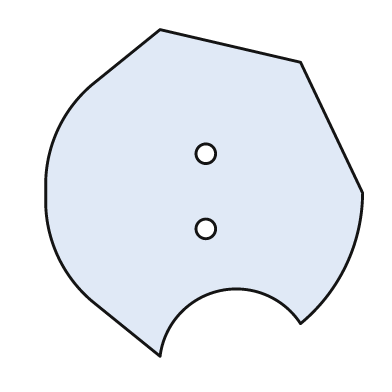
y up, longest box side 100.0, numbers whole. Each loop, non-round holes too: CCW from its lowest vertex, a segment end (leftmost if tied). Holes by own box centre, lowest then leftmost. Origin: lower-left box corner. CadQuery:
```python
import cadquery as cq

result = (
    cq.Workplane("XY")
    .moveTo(35.0, 0.0)
    .threePointArc((53.0, 20.0), (78.0, 10.0))
    .threePointArc((92.0, 28.0), (97.0, 50.0))
    .lineTo(78.0, 90.0)
    .lineTo(35.0, 100.0)
    .lineTo(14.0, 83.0)
    .threePointArc((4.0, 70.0), (0.0, 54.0))
    .lineTo(0.0, 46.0)
    .threePointArc((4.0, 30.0), (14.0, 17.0))
    .close()
    .moveTo(49.0, 39.0)
    .circle(3.0)
    .moveTo(49.0, 62.0)
    .circle(3.0)
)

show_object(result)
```